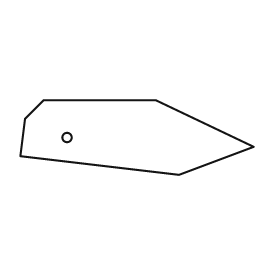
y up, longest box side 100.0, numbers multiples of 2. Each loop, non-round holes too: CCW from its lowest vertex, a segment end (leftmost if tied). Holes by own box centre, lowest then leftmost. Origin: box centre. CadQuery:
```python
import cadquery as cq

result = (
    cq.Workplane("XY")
    .moveTo(18.0, -16.0)
    .lineTo(50.0, -4.0)
    .lineTo(8.0, 16.0)
    .lineTo(-40.0, 16.0)
    .lineTo(-48.0, 8.0)
    .lineTo(-50.0, -8.0)
    .close()
    .moveTo(-30.0, 0.0)
    .circle(2.0)
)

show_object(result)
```